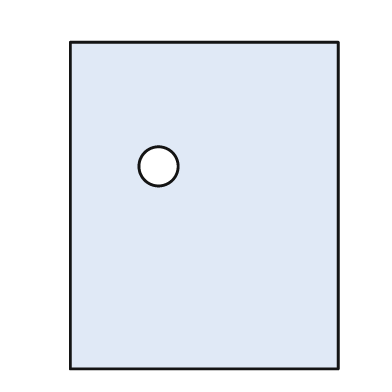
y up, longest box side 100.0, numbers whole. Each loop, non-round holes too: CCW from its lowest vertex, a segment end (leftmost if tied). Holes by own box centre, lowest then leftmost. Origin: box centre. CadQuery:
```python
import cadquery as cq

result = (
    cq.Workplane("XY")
    .moveTo(-41.0, -50.0)
    .lineTo(41.0, -50.0)
    .lineTo(41.0, 50.0)
    .lineTo(-41.0, 50.0)
    .close()
    .moveTo(-14.0, 12.0)
    .circle(6.0)
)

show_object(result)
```